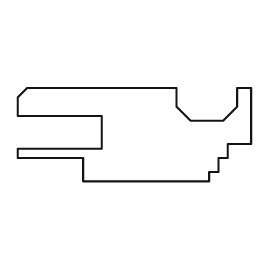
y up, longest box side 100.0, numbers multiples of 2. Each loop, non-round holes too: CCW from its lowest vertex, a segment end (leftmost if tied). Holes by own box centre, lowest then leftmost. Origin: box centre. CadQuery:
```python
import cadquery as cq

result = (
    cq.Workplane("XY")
    .moveTo(-22.0, -20.0)
    .lineTo(32.0, -20.0)
    .lineTo(32.0, -16.0)
    .lineTo(36.0, -16.0)
    .lineTo(36.0, -10.0)
    .lineTo(40.0, -10.0)
    .lineTo(40.0, -4.0)
    .lineTo(50.0, -4.0)
    .lineTo(50.0, 20.0)
    .lineTo(44.0, 20.0)
    .lineTo(44.0, 12.0)
    .lineTo(38.0, 6.0)
    .lineTo(24.0, 6.0)
    .lineTo(18.0, 12.0)
    .lineTo(18.0, 20.0)
    .lineTo(-46.0, 20.0)
    .lineTo(-50.0, 16.0)
    .lineTo(-50.0, 8.0)
    .lineTo(-14.0, 8.0)
    .lineTo(-14.0, -6.0)
    .lineTo(-50.0, -6.0)
    .lineTo(-50.0, -10.0)
    .lineTo(-22.0, -10.0)
    .close()
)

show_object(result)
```